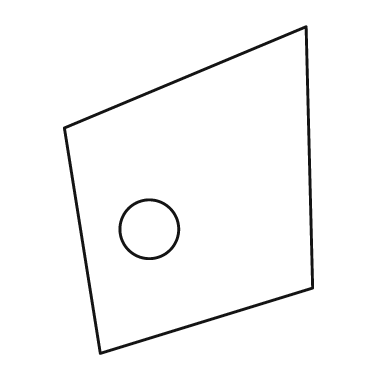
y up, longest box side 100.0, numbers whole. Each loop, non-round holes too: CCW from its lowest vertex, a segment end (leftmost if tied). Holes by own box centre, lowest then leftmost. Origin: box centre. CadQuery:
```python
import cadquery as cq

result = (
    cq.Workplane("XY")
    .moveTo(-27.0, -50.0)
    .lineTo(38.0, -30.0)
    .lineTo(36.0, 50.0)
    .lineTo(-38.0, 19.0)
    .close()
    .moveTo(-12.0, -12.0)
    .circle(9.0)
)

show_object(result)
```